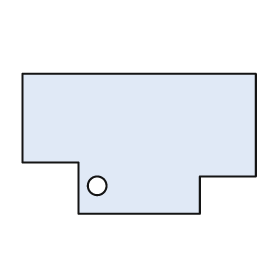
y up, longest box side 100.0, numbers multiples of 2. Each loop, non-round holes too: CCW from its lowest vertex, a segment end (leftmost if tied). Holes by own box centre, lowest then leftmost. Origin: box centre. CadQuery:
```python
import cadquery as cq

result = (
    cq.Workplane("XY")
    .moveTo(-26.0, -30.0)
    .lineTo(26.0, -30.0)
    .lineTo(26.0, -14.0)
    .lineTo(50.0, -14.0)
    .lineTo(50.0, 30.0)
    .lineTo(-50.0, 30.0)
    .lineTo(-50.0, -8.0)
    .lineTo(-26.0, -8.0)
    .close()
    .moveTo(-18.0, -18.0)
    .circle(4.0)
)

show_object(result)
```